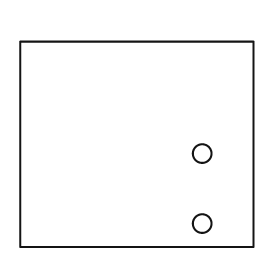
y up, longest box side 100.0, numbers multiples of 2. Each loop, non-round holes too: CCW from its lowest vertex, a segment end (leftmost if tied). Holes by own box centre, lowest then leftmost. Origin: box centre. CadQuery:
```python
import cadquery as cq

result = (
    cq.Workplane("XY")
    .moveTo(-50.0, -44.0)
    .lineTo(50.0, -44.0)
    .lineTo(50.0, 44.0)
    .lineTo(-50.0, 44.0)
    .close()
    .moveTo(28.0, -34.0)
    .circle(4.0)
    .moveTo(28.0, -4.0)
    .circle(4.0)
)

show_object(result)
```